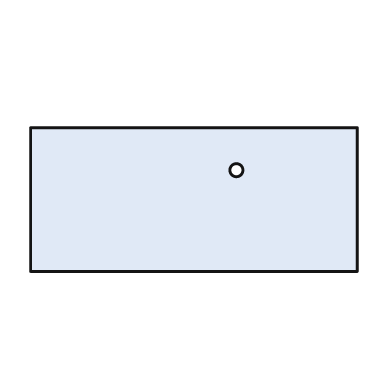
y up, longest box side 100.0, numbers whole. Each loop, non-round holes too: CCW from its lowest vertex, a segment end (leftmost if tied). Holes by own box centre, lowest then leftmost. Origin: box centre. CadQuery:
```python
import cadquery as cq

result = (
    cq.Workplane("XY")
    .moveTo(-50.0, -22.0)
    .lineTo(50.0, -22.0)
    .lineTo(50.0, 22.0)
    .lineTo(-50.0, 22.0)
    .close()
    .moveTo(13.0, 9.0)
    .circle(2.0)
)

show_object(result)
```